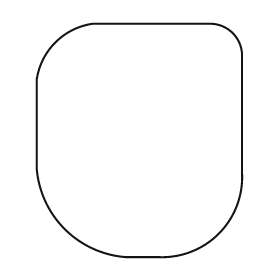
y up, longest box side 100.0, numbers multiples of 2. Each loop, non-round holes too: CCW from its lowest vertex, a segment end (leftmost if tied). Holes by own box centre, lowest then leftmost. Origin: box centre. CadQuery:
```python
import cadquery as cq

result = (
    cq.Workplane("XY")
    .moveTo(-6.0, -50.0)
    .lineTo(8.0, -50.0)
    .threePointArc((34.0, -40.0), (44.0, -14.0))
    .lineTo(44.0, 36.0)
    .threePointArc((40.0, 46.0), (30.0, 50.0))
    .lineTo(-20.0, 50.0)
    .threePointArc((-36.0, 42.0), (-44.0, 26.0))
    .lineTo(-44.0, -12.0)
    .threePointArc((-32.0, -38.0), (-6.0, -50.0))
    .close()
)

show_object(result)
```